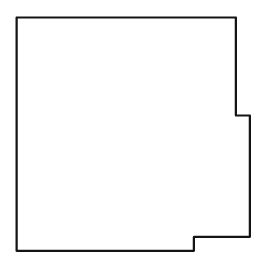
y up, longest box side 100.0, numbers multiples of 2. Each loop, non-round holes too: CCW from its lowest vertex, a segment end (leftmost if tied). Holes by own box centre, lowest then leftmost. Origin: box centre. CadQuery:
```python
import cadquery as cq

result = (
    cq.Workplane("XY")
    .moveTo(-50.0, -50.0)
    .lineTo(26.0, -50.0)
    .lineTo(26.0, -44.0)
    .lineTo(50.0, -44.0)
    .lineTo(50.0, 8.0)
    .lineTo(44.0, 8.0)
    .lineTo(44.0, 50.0)
    .lineTo(-50.0, 50.0)
    .close()
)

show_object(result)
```